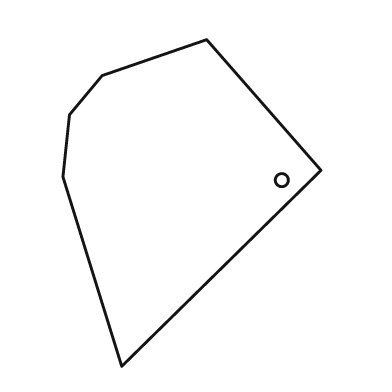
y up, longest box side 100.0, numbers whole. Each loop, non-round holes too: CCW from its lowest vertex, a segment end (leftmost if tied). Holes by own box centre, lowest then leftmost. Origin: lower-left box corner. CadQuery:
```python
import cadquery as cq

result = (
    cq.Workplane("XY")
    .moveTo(18.0, 0.0)
    .lineTo(79.0, 60.0)
    .lineTo(44.0, 100.0)
    .lineTo(12.0, 89.0)
    .lineTo(2.0, 77.0)
    .lineTo(0.0, 58.0)
    .close()
    .moveTo(67.0, 57.0)
    .circle(2.0)
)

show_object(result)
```